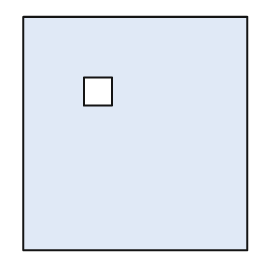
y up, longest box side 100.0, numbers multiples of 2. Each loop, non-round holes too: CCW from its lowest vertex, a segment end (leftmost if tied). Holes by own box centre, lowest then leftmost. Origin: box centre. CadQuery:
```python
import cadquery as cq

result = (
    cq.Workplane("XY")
    .moveTo(-48.0, -50.0)
    .lineTo(48.0, -50.0)
    .lineTo(48.0, 50.0)
    .lineTo(-48.0, 50.0)
    .close()
    .moveTo(-22.0, 12.0)
    .lineTo(-10.0, 12.0)
    .lineTo(-10.0, 24.0)
    .lineTo(-22.0, 24.0)
    .close()
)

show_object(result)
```